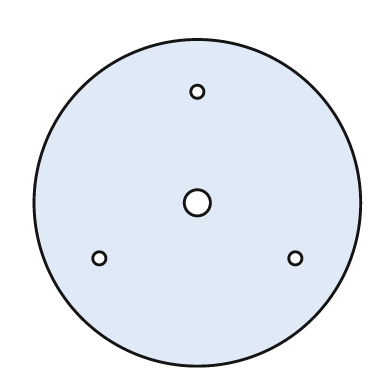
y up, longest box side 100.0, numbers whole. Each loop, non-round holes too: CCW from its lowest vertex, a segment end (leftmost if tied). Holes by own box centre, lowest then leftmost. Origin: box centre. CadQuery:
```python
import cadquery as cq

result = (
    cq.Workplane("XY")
    .moveTo(0.0, 0.0)
    .circle(50.0)
    .moveTo(-30.0, -17.0)
    .circle(2.0)
    .moveTo(30.0, -17.0)
    .circle(2.0)
    .moveTo(0.0, 0.0)
    .circle(4.0)
    .moveTo(0.0, 34.0)
    .circle(2.0)
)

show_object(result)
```